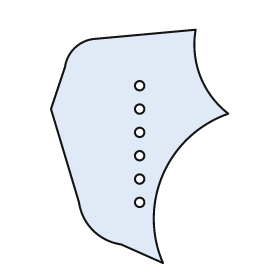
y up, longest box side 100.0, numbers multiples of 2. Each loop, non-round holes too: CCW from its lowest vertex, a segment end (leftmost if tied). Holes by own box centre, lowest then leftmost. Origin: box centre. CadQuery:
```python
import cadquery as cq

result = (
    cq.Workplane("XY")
    .moveTo(10.0, -50.0)
    .threePointArc((10.0, -12.0), (38.0, 14.0))
    .threePointArc((26.0, 30.0), (24.0, 50.0))
    .lineTo(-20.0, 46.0)
    .threePointArc((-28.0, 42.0), (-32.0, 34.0))
    .lineTo(-38.0, 16.0)
    .lineTo(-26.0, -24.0)
    .threePointArc((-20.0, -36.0), (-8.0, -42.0))
    .close()
    .moveTo(0.0, -24.0)
    .circle(2.0)
    .moveTo(0.0, -14.0)
    .circle(2.0)
    .moveTo(0.0, -4.0)
    .circle(2.0)
    .moveTo(0.0, 6.0)
    .circle(2.0)
    .moveTo(0.0, 16.0)
    .circle(2.0)
    .moveTo(0.0, 26.0)
    .circle(2.0)
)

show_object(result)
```